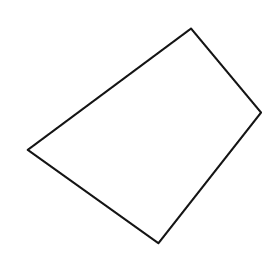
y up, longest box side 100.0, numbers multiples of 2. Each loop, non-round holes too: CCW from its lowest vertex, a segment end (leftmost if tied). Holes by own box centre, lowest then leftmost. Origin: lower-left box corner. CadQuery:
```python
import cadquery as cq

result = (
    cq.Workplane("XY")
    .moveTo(56.0, 0.0)
    .lineTo(100.0, 56.0)
    .lineTo(70.0, 92.0)
    .lineTo(0.0, 40.0)
    .close()
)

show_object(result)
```